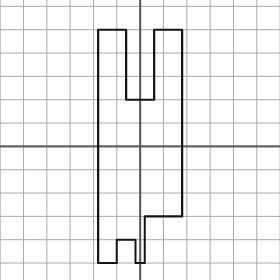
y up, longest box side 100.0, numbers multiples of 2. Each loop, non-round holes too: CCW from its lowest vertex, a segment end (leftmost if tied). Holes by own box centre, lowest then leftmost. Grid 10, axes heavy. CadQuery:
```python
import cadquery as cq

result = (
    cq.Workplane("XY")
    .moveTo(-18.0, -50.0)
    .lineTo(-10.0, -50.0)
    .lineTo(-10.0, -40.0)
    .lineTo(-2.0, -40.0)
    .lineTo(-2.0, -50.0)
    .lineTo(2.0, -50.0)
    .lineTo(2.0, -30.0)
    .lineTo(18.0, -30.0)
    .lineTo(18.0, 50.0)
    .lineTo(6.0, 50.0)
    .lineTo(6.0, 20.0)
    .lineTo(-6.0, 20.0)
    .lineTo(-6.0, 50.0)
    .lineTo(-18.0, 50.0)
    .close()
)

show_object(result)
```